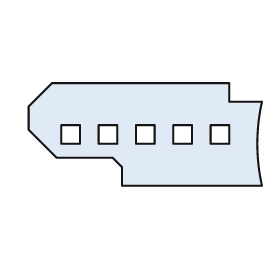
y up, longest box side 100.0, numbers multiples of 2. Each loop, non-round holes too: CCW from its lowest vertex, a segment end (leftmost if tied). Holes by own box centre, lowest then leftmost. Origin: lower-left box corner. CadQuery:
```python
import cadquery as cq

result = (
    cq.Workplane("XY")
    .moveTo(40.0, 0.0)
    .lineTo(100.0, 0.0)
    .threePointArc((98.0, 18.0), (100.0, 36.0))
    .lineTo(86.0, 36.0)
    .lineTo(86.0, 44.0)
    .lineTo(10.0, 44.0)
    .lineTo(0.0, 34.0)
    .lineTo(0.0, 24.0)
    .lineTo(12.0, 12.0)
    .lineTo(36.0, 12.0)
    .lineTo(40.0, 8.0)
    .close()
    .moveTo(14.0, 18.0)
    .lineTo(22.0, 18.0)
    .lineTo(22.0, 26.0)
    .lineTo(14.0, 26.0)
    .close()
    .moveTo(30.0, 18.0)
    .lineTo(38.0, 18.0)
    .lineTo(38.0, 26.0)
    .lineTo(30.0, 26.0)
    .close()
    .moveTo(46.0, 18.0)
    .lineTo(54.0, 18.0)
    .lineTo(54.0, 26.0)
    .lineTo(46.0, 26.0)
    .close()
    .moveTo(62.0, 18.0)
    .lineTo(70.0, 18.0)
    .lineTo(70.0, 26.0)
    .lineTo(62.0, 26.0)
    .close()
    .moveTo(78.0, 18.0)
    .lineTo(86.0, 18.0)
    .lineTo(86.0, 26.0)
    .lineTo(78.0, 26.0)
    .close()
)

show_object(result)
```